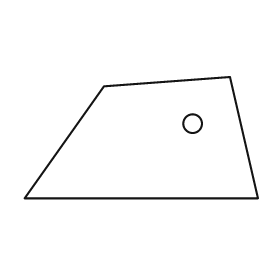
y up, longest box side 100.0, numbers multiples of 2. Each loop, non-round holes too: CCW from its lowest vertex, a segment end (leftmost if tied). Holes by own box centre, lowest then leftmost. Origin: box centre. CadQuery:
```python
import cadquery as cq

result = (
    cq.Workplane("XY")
    .moveTo(-50.0, -26.0)
    .lineTo(50.0, -26.0)
    .lineTo(38.0, 26.0)
    .lineTo(-16.0, 22.0)
    .close()
    .moveTo(22.0, 6.0)
    .circle(4.0)
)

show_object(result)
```